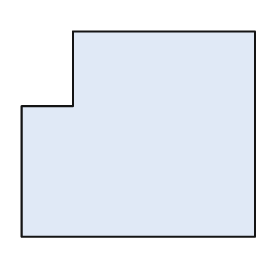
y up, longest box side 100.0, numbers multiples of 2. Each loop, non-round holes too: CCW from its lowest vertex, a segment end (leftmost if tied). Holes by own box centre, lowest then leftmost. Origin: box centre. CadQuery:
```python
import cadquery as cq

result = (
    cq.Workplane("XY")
    .moveTo(-50.0, -44.0)
    .lineTo(50.0, -44.0)
    .lineTo(50.0, 44.0)
    .lineTo(-28.0, 44.0)
    .lineTo(-28.0, 12.0)
    .lineTo(-50.0, 12.0)
    .close()
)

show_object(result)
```